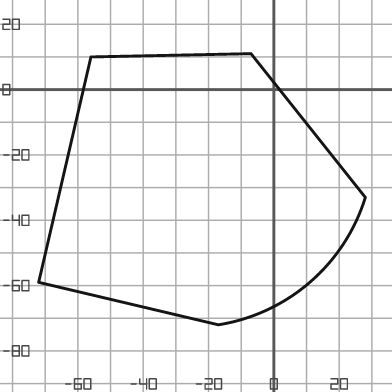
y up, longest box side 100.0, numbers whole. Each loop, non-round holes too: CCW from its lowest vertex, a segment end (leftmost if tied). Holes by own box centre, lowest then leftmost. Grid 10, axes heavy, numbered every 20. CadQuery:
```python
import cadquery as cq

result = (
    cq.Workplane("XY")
    .moveTo(-17.0, -72.0)
    .threePointArc((11.0, -59.0), (28.0, -33.0))
    .lineTo(-7.0, 11.0)
    .lineTo(-56.0, 10.0)
    .lineTo(-72.0, -59.0)
    .close()
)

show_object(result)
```